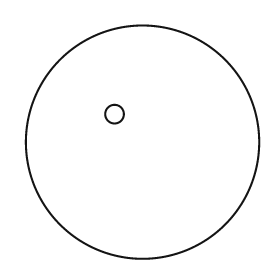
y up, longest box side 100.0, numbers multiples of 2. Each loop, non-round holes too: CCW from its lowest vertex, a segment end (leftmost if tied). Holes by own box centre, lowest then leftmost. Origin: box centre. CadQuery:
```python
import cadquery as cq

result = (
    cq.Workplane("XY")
    .moveTo(0.0, 0.0)
    .circle(50.0)
    .moveTo(-12.0, 12.0)
    .circle(4.0)
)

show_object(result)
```